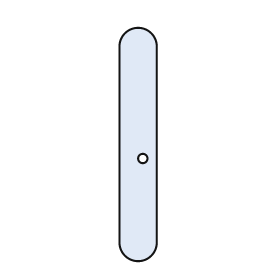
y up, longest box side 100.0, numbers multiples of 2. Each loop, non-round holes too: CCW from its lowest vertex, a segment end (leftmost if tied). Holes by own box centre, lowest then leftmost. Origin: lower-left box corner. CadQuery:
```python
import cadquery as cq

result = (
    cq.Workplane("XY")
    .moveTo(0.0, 8.0)
    .threePointArc((8.0, 0.0), (16.0, 8.0))
    .lineTo(16.0, 92.0)
    .threePointArc((8.0, 100.0), (0.0, 92.0))
    .close()
    .moveTo(10.0, 44.0)
    .circle(2.0)
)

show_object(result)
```